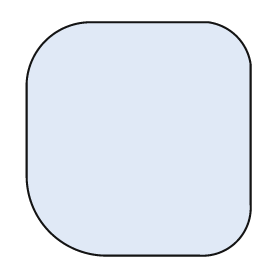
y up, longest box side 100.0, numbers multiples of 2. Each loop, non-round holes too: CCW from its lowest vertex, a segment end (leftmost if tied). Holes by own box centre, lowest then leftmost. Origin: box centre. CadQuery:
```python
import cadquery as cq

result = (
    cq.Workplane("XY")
    .moveTo(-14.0, -50.0)
    .lineTo(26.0, -50.0)
    .threePointArc((42.0, -44.0), (48.0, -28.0))
    .lineTo(48.0, 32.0)
    .threePointArc((42.0, 44.0), (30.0, 50.0))
    .lineTo(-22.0, 50.0)
    .threePointArc((-40.0, 42.0), (-48.0, 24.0))
    .lineTo(-48.0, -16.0)
    .threePointArc((-38.0, -40.0), (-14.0, -50.0))
    .close()
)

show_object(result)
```